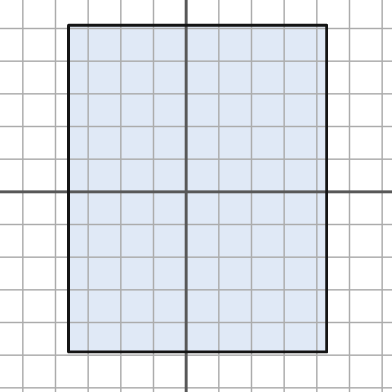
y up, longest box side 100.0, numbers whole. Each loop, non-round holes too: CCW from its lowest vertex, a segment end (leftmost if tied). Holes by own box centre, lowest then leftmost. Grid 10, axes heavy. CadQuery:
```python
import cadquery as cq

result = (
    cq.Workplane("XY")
    .moveTo(-36.0, -49.0)
    .lineTo(43.0, -49.0)
    .lineTo(43.0, 51.0)
    .lineTo(-36.0, 51.0)
    .close()
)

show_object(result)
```